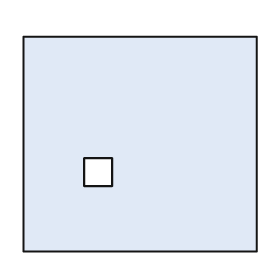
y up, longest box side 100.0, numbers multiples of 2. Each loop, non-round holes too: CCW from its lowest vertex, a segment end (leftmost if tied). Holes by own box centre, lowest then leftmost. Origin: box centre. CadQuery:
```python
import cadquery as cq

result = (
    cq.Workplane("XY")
    .moveTo(-50.0, -46.0)
    .lineTo(50.0, -46.0)
    .lineTo(50.0, 46.0)
    .lineTo(-50.0, 46.0)
    .close()
    .moveTo(-24.0, -18.0)
    .lineTo(-12.0, -18.0)
    .lineTo(-12.0, -6.0)
    .lineTo(-24.0, -6.0)
    .close()
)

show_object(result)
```